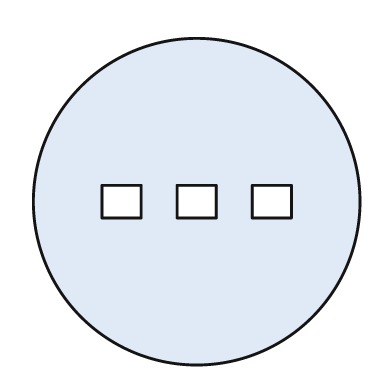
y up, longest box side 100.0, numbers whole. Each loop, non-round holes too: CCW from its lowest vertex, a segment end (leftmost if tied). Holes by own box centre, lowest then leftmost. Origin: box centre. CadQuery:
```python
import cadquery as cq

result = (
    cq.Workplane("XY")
    .moveTo(0.0, 0.0)
    .circle(50.0)
    .moveTo(-29.0, -5.0)
    .lineTo(-17.0, -5.0)
    .lineTo(-17.0, 5.0)
    .lineTo(-29.0, 5.0)
    .close()
    .moveTo(-6.0, -5.0)
    .lineTo(6.0, -5.0)
    .lineTo(6.0, 5.0)
    .lineTo(-6.0, 5.0)
    .close()
    .moveTo(17.0, -5.0)
    .lineTo(29.0, -5.0)
    .lineTo(29.0, 5.0)
    .lineTo(17.0, 5.0)
    .close()
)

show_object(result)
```